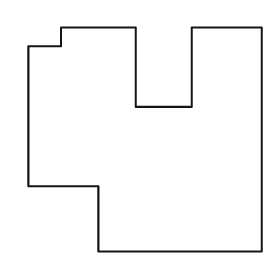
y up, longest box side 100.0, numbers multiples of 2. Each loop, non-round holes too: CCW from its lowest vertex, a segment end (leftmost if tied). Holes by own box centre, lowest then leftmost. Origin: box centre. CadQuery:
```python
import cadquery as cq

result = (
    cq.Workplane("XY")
    .moveTo(-20.0, -48.0)
    .lineTo(50.0, -48.0)
    .lineTo(50.0, 48.0)
    .lineTo(20.0, 48.0)
    .lineTo(20.0, 14.0)
    .lineTo(-4.0, 14.0)
    .lineTo(-4.0, 48.0)
    .lineTo(-36.0, 48.0)
    .lineTo(-36.0, 40.0)
    .lineTo(-50.0, 40.0)
    .lineTo(-50.0, -20.0)
    .lineTo(-20.0, -20.0)
    .close()
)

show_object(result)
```